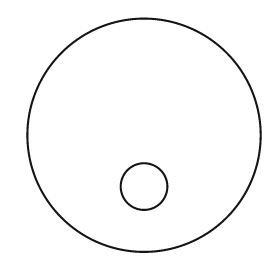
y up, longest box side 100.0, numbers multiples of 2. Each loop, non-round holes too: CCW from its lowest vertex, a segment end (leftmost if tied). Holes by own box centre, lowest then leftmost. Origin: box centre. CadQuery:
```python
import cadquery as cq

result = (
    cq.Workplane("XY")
    .moveTo(0.0, 0.0)
    .circle(50.0)
    .moveTo(0.0, -22.0)
    .circle(10.0)
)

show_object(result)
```